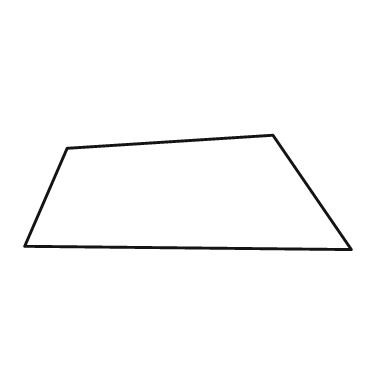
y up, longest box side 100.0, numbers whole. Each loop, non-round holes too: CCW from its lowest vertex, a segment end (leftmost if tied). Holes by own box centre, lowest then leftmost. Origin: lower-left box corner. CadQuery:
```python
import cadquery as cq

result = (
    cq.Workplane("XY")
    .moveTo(100.0, 0.0)
    .lineTo(76.0, 35.0)
    .lineTo(13.0, 31.0)
    .lineTo(0.0, 1.0)
    .close()
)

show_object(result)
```